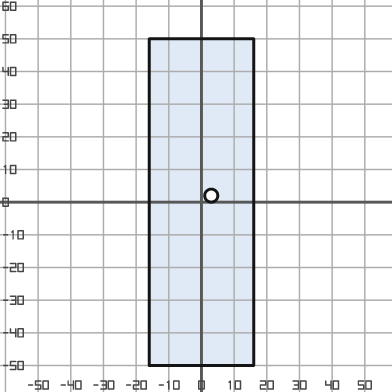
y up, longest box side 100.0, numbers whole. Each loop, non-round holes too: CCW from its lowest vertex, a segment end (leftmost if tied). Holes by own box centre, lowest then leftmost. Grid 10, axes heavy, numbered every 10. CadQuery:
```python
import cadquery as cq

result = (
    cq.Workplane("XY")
    .moveTo(-16.0, -50.0)
    .lineTo(16.0, -50.0)
    .lineTo(16.0, 50.0)
    .lineTo(-16.0, 50.0)
    .close()
    .moveTo(3.0, 2.0)
    .circle(2.0)
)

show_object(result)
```